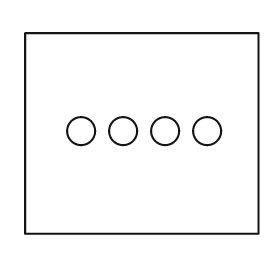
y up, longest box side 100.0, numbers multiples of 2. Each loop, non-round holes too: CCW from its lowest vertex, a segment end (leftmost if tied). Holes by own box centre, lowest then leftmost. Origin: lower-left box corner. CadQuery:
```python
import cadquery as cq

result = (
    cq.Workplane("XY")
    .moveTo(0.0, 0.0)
    .lineTo(100.0, 0.0)
    .lineTo(100.0, 86.0)
    .lineTo(0.0, 86.0)
    .close()
    .moveTo(24.0, 44.0)
    .circle(6.0)
    .moveTo(42.0, 44.0)
    .circle(6.0)
    .moveTo(60.0, 44.0)
    .circle(6.0)
    .moveTo(78.0, 44.0)
    .circle(6.0)
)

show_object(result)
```